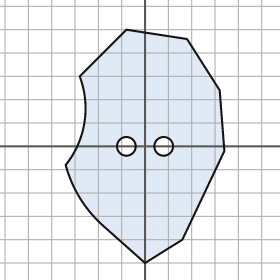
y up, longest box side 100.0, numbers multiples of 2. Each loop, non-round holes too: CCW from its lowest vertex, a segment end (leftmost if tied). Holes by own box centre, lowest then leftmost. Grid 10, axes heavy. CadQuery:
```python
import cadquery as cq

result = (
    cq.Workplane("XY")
    .moveTo(0.0, -50.0)
    .lineTo(16.0, -40.0)
    .lineTo(34.0, -2.0)
    .lineTo(32.0, 24.0)
    .lineTo(18.0, 46.0)
    .lineTo(-8.0, 50.0)
    .lineTo(-28.0, 30.0)
    .threePointArc((-26.0, 10.0), (-34.0, -8.0))
    .threePointArc((-28.0, -22.0), (-18.0, -34.0))
    .close()
    .moveTo(-8.0, 0.0)
    .circle(4.0)
    .moveTo(8.0, 0.0)
    .circle(4.0)
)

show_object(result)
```